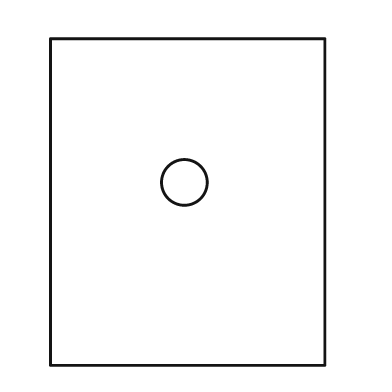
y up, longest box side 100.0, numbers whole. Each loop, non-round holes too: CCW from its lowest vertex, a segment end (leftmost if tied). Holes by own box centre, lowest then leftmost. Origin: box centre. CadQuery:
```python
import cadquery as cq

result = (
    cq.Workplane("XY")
    .moveTo(-42.0, -50.0)
    .lineTo(42.0, -50.0)
    .lineTo(42.0, 50.0)
    .lineTo(-42.0, 50.0)
    .close()
    .moveTo(-1.0, 6.0)
    .circle(7.0)
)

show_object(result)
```